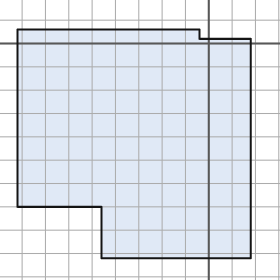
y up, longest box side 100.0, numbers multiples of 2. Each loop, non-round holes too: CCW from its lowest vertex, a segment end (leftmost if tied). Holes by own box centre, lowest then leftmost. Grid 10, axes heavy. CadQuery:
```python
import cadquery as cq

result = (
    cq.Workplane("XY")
    .moveTo(-46.0, -92.0)
    .lineTo(18.0, -92.0)
    .lineTo(18.0, 2.0)
    .lineTo(-4.0, 2.0)
    .lineTo(-4.0, 6.0)
    .lineTo(-82.0, 6.0)
    .lineTo(-82.0, -70.0)
    .lineTo(-46.0, -70.0)
    .close()
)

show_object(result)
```